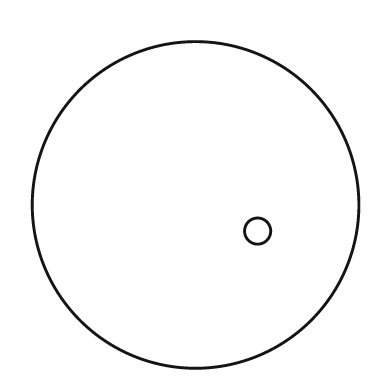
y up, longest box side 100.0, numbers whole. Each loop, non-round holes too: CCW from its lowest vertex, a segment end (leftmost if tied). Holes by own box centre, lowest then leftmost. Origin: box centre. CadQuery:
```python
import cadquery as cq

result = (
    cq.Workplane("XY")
    .moveTo(0.0, 0.0)
    .circle(50.0)
    .moveTo(19.0, -8.0)
    .circle(4.0)
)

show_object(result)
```